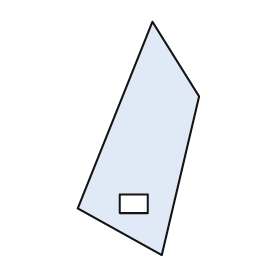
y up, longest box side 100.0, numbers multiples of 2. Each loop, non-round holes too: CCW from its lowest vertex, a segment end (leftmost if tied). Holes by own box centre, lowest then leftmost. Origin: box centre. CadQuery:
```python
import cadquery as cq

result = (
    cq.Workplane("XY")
    .moveTo(10.0, -50.0)
    .lineTo(26.0, 18.0)
    .lineTo(6.0, 50.0)
    .lineTo(-26.0, -30.0)
    .close()
    .moveTo(-8.0, -32.0)
    .lineTo(4.0, -32.0)
    .lineTo(4.0, -24.0)
    .lineTo(-8.0, -24.0)
    .close()
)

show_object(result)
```